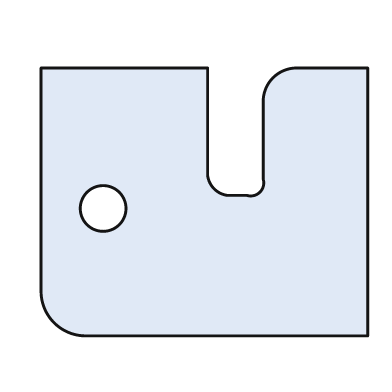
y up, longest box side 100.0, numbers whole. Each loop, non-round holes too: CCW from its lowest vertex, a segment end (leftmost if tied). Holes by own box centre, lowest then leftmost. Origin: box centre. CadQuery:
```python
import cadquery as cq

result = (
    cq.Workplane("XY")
    .moveTo(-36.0, -41.0)
    .lineTo(50.0, -41.0)
    .lineTo(50.0, 41.0)
    .lineTo(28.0, 41.0)
    .threePointArc((21.0, 38.0), (18.0, 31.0))
    .lineTo(18.0, 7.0)
    .threePointArc((17.0, 3.0), (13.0, 2.0))
    .lineTo(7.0, 2.0)
    .threePointArc((3.0, 4.0), (1.0, 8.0))
    .lineTo(1.0, 41.0)
    .lineTo(-50.0, 41.0)
    .lineTo(-50.0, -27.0)
    .threePointArc((-46.0, -37.0), (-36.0, -41.0))
    .close()
    .moveTo(-31.0, -2.0)
    .circle(7.0)
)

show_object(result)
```